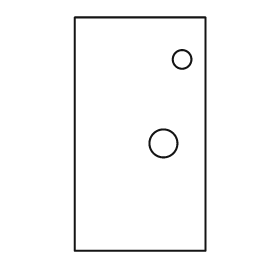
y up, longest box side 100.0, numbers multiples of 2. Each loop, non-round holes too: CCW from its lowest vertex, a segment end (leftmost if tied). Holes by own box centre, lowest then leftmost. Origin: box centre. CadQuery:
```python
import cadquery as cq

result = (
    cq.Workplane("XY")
    .moveTo(-28.0, -50.0)
    .lineTo(28.0, -50.0)
    .lineTo(28.0, 50.0)
    .lineTo(-28.0, 50.0)
    .close()
    .moveTo(10.0, -4.0)
    .circle(6.0)
    .moveTo(18.0, 32.0)
    .circle(4.0)
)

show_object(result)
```